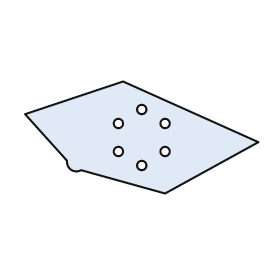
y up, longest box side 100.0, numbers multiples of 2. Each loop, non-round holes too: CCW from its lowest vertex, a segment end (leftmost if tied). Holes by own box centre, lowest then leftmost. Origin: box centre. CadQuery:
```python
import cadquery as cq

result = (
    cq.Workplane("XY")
    .moveTo(10.0, -24.0)
    .lineTo(50.0, -2.0)
    .lineTo(-8.0, 24.0)
    .lineTo(-50.0, 10.0)
    .lineTo(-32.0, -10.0)
    .threePointArc((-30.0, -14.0), (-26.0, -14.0))
    .close()
    .moveTo(0.0, -12.0)
    .circle(2.0)
    .moveTo(-10.0, -6.0)
    .circle(2.0)
    .moveTo(10.0, -6.0)
    .circle(2.0)
    .moveTo(-10.0, 6.0)
    .circle(2.0)
    .moveTo(10.0, 6.0)
    .circle(2.0)
    .moveTo(0.0, 12.0)
    .circle(2.0)
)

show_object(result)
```